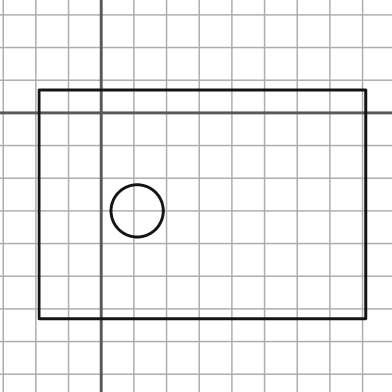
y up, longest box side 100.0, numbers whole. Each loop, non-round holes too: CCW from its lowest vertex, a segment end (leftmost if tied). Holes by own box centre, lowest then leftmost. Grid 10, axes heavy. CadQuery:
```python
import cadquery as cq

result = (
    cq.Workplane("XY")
    .moveTo(-19.0, -63.0)
    .lineTo(81.0, -63.0)
    .lineTo(81.0, 7.0)
    .lineTo(-19.0, 7.0)
    .close()
    .moveTo(11.0, -30.0)
    .circle(8.0)
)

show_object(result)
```